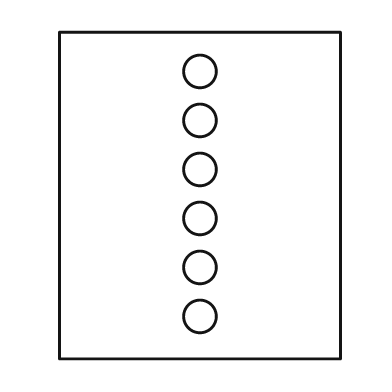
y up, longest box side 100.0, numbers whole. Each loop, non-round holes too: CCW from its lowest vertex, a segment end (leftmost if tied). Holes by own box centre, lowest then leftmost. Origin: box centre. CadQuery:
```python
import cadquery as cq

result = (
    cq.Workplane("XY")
    .moveTo(-43.0, -50.0)
    .lineTo(43.0, -50.0)
    .lineTo(43.0, 50.0)
    .lineTo(-43.0, 50.0)
    .close()
    .moveTo(0.0, -37.0)
    .circle(5.0)
    .moveTo(0.0, -22.0)
    .circle(5.0)
    .moveTo(0.0, -7.0)
    .circle(5.0)
    .moveTo(0.0, 8.0)
    .circle(5.0)
    .moveTo(0.0, 23.0)
    .circle(5.0)
    .moveTo(0.0, 38.0)
    .circle(5.0)
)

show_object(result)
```